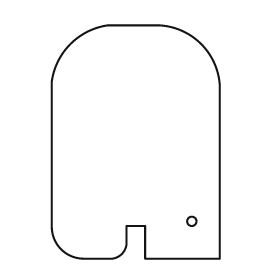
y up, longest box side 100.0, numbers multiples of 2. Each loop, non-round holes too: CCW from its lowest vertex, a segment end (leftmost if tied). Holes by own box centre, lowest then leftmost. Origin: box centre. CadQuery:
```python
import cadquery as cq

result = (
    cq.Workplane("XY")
    .moveTo(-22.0, -50.0)
    .lineTo(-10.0, -50.0)
    .threePointArc((-6.0, -48.0), (-4.0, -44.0))
    .lineTo(-4.0, -36.0)
    .lineTo(4.0, -36.0)
    .lineTo(4.0, -50.0)
    .lineTo(36.0, -50.0)
    .lineTo(36.0, 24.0)
    .threePointArc((28.0, 42.0), (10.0, 50.0))
    .lineTo(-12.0, 50.0)
    .threePointArc((-28.0, 42.0), (-36.0, 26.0))
    .lineTo(-36.0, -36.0)
    .threePointArc((-32.0, -46.0), (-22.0, -50.0))
    .close()
    .moveTo(24.0, -34.0)
    .circle(2.0)
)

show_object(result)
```